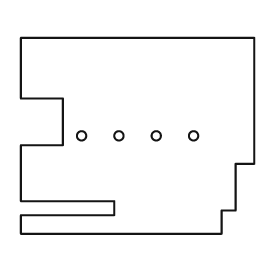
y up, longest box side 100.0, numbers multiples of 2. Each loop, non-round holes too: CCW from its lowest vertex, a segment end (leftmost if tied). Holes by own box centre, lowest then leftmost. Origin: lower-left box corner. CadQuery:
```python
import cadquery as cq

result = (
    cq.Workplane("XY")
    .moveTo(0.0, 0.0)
    .lineTo(86.0, 0.0)
    .lineTo(86.0, 10.0)
    .lineTo(92.0, 10.0)
    .lineTo(92.0, 30.0)
    .lineTo(100.0, 30.0)
    .lineTo(100.0, 84.0)
    .lineTo(0.0, 84.0)
    .lineTo(0.0, 58.0)
    .lineTo(18.0, 58.0)
    .lineTo(18.0, 38.0)
    .lineTo(0.0, 38.0)
    .lineTo(0.0, 14.0)
    .lineTo(40.0, 14.0)
    .lineTo(40.0, 8.0)
    .lineTo(0.0, 8.0)
    .close()
    .moveTo(26.0, 42.0)
    .circle(2.0)
    .moveTo(42.0, 42.0)
    .circle(2.0)
    .moveTo(58.0, 42.0)
    .circle(2.0)
    .moveTo(74.0, 42.0)
    .circle(2.0)
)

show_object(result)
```